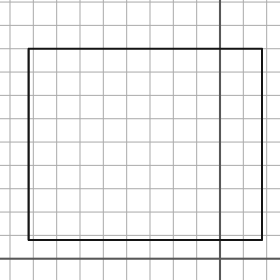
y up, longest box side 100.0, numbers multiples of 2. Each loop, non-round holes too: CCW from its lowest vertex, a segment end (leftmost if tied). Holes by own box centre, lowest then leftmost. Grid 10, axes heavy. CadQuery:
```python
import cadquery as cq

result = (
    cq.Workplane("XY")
    .moveTo(-82.0, 8.0)
    .lineTo(18.0, 8.0)
    .lineTo(18.0, 90.0)
    .lineTo(-82.0, 90.0)
    .close()
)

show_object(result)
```